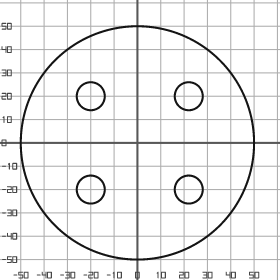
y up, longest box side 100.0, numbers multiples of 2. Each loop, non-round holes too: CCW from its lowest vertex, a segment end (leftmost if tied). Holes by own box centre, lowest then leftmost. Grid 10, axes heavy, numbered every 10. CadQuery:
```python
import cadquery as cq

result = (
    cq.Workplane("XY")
    .moveTo(0.0, 0.0)
    .circle(50.0)
    .moveTo(-20.0, -20.0)
    .circle(6.0)
    .moveTo(22.0, -20.0)
    .circle(6.0)
    .moveTo(-20.0, 20.0)
    .circle(6.0)
    .moveTo(22.0, 20.0)
    .circle(6.0)
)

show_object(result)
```